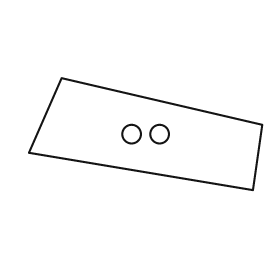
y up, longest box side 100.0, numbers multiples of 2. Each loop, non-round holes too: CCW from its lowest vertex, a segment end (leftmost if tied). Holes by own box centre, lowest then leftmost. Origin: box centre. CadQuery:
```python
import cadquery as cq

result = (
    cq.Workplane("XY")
    .moveTo(46.0, -24.0)
    .lineTo(50.0, 4.0)
    .lineTo(-36.0, 24.0)
    .lineTo(-50.0, -8.0)
    .close()
    .moveTo(-6.0, 0.0)
    .circle(4.0)
    .moveTo(6.0, 0.0)
    .circle(4.0)
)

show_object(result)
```